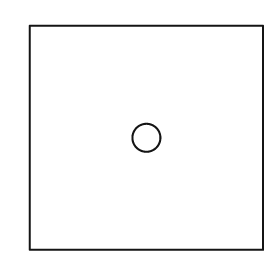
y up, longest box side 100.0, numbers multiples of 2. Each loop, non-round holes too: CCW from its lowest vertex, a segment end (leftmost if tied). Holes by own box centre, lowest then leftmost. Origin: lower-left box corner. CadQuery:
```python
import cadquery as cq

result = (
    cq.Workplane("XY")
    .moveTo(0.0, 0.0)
    .lineTo(100.0, 0.0)
    .lineTo(100.0, 96.0)
    .lineTo(0.0, 96.0)
    .close()
    .moveTo(50.0, 48.0)
    .circle(6.0)
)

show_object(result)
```